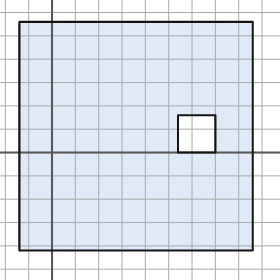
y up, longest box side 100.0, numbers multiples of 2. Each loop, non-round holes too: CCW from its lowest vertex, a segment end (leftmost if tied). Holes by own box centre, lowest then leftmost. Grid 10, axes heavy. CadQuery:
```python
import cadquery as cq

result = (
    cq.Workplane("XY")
    .moveTo(-14.0, -42.0)
    .lineTo(86.0, -42.0)
    .lineTo(86.0, 56.0)
    .lineTo(-14.0, 56.0)
    .close()
    .moveTo(54.0, 0.0)
    .lineTo(70.0, 0.0)
    .lineTo(70.0, 16.0)
    .lineTo(54.0, 16.0)
    .close()
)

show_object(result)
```